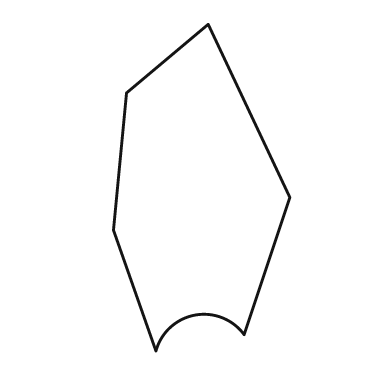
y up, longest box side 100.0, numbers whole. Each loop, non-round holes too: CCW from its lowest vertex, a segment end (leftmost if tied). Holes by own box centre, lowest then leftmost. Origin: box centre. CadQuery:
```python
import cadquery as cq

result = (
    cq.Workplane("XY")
    .moveTo(-14.0, -50.0)
    .threePointArc((-2.0, -39.0), (13.0, -45.0))
    .lineTo(27.0, -3.0)
    .lineTo(2.0, 50.0)
    .lineTo(-23.0, 29.0)
    .lineTo(-27.0, -13.0)
    .close()
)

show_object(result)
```